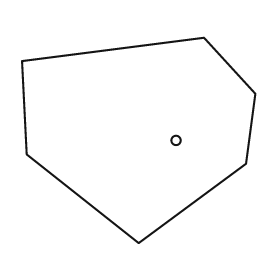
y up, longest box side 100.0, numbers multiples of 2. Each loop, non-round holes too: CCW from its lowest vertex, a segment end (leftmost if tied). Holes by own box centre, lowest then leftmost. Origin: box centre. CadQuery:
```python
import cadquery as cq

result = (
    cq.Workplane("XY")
    .moveTo(0.0, -44.0)
    .lineTo(46.0, -10.0)
    .lineTo(50.0, 20.0)
    .lineTo(28.0, 44.0)
    .lineTo(-50.0, 34.0)
    .lineTo(-48.0, -6.0)
    .close()
    .moveTo(16.0, 0.0)
    .circle(2.0)
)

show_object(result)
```